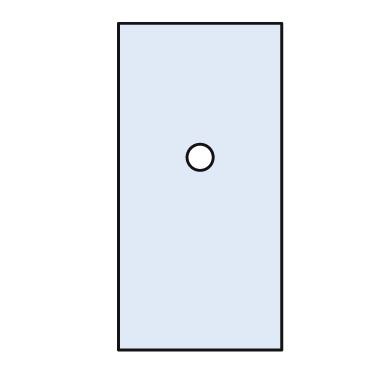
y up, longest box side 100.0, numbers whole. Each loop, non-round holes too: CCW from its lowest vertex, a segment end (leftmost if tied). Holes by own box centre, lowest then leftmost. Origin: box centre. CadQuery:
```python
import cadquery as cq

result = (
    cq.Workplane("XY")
    .moveTo(-25.0, -50.0)
    .lineTo(25.0, -50.0)
    .lineTo(25.0, 50.0)
    .lineTo(-25.0, 50.0)
    .close()
    .moveTo(0.0, 9.0)
    .circle(4.0)
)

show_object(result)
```